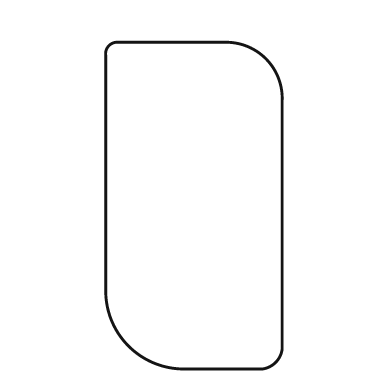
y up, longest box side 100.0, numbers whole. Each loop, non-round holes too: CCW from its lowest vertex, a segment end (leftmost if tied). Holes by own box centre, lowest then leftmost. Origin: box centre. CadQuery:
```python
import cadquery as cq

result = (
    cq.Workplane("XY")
    .moveTo(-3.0, -50.0)
    .lineTo(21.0, -50.0)
    .threePointArc((25.0, -48.0), (27.0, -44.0))
    .lineTo(27.0, 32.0)
    .threePointArc((22.0, 45.0), (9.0, 50.0))
    .lineTo(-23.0, 50.0)
    .threePointArc((-26.0, 49.0), (-27.0, 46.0))
    .lineTo(-27.0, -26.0)
    .threePointArc((-20.0, -43.0), (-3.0, -50.0))
    .close()
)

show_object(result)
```